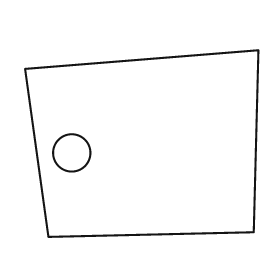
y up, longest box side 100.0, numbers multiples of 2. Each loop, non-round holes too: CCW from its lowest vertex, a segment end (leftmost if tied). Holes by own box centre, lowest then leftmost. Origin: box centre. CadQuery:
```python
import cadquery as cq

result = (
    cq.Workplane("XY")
    .moveTo(-40.0, -40.0)
    .lineTo(48.0, -38.0)
    .lineTo(50.0, 40.0)
    .lineTo(-50.0, 32.0)
    .close()
    .moveTo(-30.0, -4.0)
    .circle(8.0)
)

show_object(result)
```